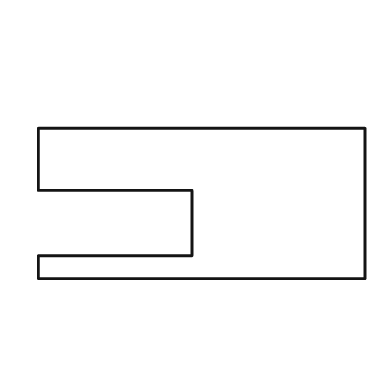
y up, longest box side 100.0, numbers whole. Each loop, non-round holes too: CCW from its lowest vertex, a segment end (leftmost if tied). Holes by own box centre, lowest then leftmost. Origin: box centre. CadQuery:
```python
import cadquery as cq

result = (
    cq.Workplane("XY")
    .moveTo(-50.0, -23.0)
    .lineTo(50.0, -23.0)
    .lineTo(50.0, 23.0)
    .lineTo(-50.0, 23.0)
    .lineTo(-50.0, 4.0)
    .lineTo(-3.0, 4.0)
    .lineTo(-3.0, -16.0)
    .lineTo(-50.0, -16.0)
    .close()
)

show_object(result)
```